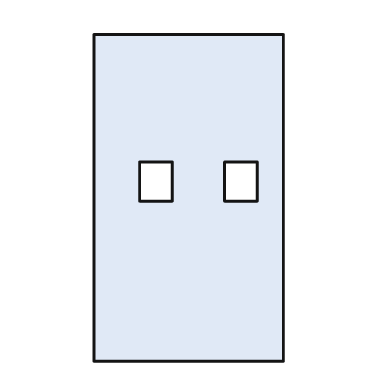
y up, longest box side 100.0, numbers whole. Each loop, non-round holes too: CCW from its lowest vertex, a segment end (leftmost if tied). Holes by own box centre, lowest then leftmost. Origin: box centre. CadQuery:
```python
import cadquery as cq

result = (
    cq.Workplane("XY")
    .moveTo(-29.0, -50.0)
    .lineTo(29.0, -50.0)
    .lineTo(29.0, 50.0)
    .lineTo(-29.0, 50.0)
    .close()
    .moveTo(-15.0, -1.0)
    .lineTo(-5.0, -1.0)
    .lineTo(-5.0, 11.0)
    .lineTo(-15.0, 11.0)
    .close()
    .moveTo(11.0, -1.0)
    .lineTo(21.0, -1.0)
    .lineTo(21.0, 11.0)
    .lineTo(11.0, 11.0)
    .close()
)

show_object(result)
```